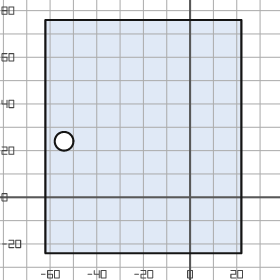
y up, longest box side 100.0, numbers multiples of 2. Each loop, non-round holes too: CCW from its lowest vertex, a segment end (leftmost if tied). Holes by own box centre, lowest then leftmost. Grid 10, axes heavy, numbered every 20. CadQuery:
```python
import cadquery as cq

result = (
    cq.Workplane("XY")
    .moveTo(-62.0, -24.0)
    .lineTo(22.0, -24.0)
    .lineTo(22.0, 76.0)
    .lineTo(-62.0, 76.0)
    .close()
    .moveTo(-54.0, 24.0)
    .circle(4.0)
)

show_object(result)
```